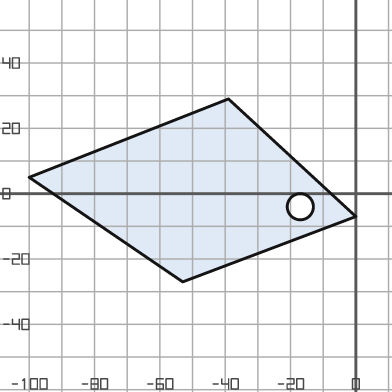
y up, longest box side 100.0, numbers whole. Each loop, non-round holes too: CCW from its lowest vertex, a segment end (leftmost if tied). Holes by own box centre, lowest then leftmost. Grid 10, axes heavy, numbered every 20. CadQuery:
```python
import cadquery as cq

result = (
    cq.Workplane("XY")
    .moveTo(-53.0, -27.0)
    .lineTo(0.0, -7.0)
    .lineTo(-39.0, 29.0)
    .lineTo(-100.0, 5.0)
    .close()
    .moveTo(-17.0, -4.0)
    .circle(4.0)
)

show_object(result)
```